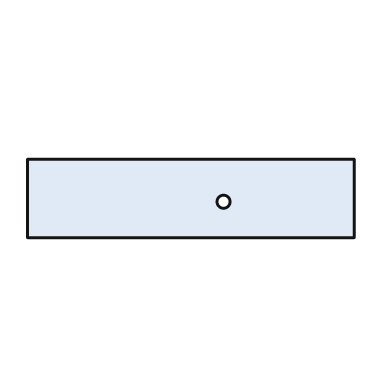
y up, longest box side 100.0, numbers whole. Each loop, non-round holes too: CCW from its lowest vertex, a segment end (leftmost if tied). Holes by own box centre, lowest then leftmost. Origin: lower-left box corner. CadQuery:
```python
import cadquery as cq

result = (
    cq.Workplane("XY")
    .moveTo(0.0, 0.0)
    .lineTo(100.0, 0.0)
    .lineTo(100.0, 24.0)
    .lineTo(0.0, 24.0)
    .close()
    .moveTo(60.0, 11.0)
    .circle(2.0)
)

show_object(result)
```